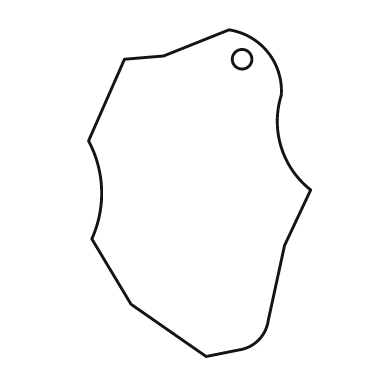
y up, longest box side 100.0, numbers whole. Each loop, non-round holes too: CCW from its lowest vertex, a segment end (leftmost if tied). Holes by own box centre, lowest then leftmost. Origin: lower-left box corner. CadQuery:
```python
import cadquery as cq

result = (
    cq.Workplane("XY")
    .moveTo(36.0, 0.0)
    .lineTo(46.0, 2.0)
    .threePointArc((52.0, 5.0), (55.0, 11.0))
    .lineTo(60.0, 34.0)
    .lineTo(68.0, 51.0)
    .threePointArc((59.0, 64.0), (59.0, 80.0))
    .threePointArc((55.0, 93.0), (43.0, 100.0))
    .lineTo(23.0, 92.0)
    .lineTo(11.0, 91.0)
    .lineTo(0.0, 66.0)
    .threePointArc((4.0, 51.0), (1.0, 36.0))
    .lineTo(13.0, 16.0)
    .close()
    .moveTo(47.0, 91.0)
    .circle(3.0)
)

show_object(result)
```